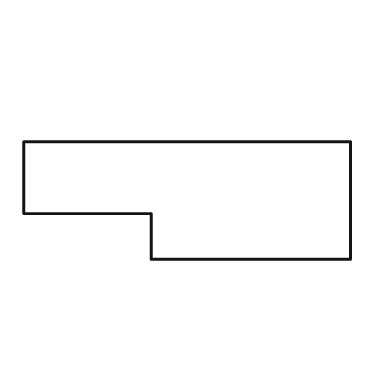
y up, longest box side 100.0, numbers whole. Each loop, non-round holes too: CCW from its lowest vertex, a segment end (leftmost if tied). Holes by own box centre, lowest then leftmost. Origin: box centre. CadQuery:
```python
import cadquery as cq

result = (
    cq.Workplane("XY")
    .moveTo(-11.0, -18.0)
    .lineTo(50.0, -18.0)
    .lineTo(50.0, 18.0)
    .lineTo(-50.0, 18.0)
    .lineTo(-50.0, -4.0)
    .lineTo(-11.0, -4.0)
    .close()
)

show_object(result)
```